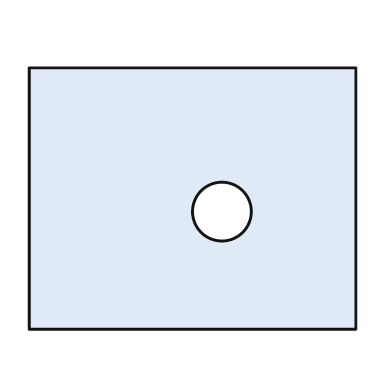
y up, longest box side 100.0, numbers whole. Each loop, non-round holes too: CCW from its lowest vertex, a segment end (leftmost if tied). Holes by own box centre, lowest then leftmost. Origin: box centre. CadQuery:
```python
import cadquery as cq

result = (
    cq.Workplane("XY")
    .moveTo(-50.0, -40.0)
    .lineTo(50.0, -40.0)
    .lineTo(50.0, 40.0)
    .lineTo(-50.0, 40.0)
    .close()
    .moveTo(9.0, -4.0)
    .circle(9.0)
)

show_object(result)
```